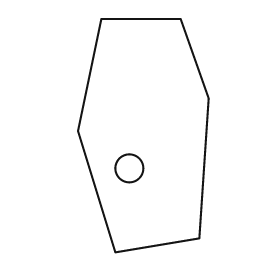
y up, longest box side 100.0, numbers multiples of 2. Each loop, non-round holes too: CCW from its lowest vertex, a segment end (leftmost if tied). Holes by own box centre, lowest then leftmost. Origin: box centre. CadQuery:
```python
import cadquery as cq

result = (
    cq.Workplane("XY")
    .moveTo(-12.0, -50.0)
    .lineTo(24.0, -44.0)
    .lineTo(28.0, 16.0)
    .lineTo(16.0, 50.0)
    .lineTo(-18.0, 50.0)
    .lineTo(-28.0, 2.0)
    .close()
    .moveTo(-6.0, -14.0)
    .circle(6.0)
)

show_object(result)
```